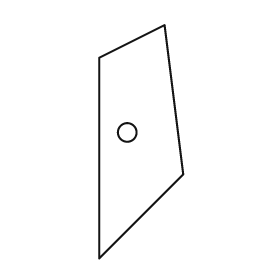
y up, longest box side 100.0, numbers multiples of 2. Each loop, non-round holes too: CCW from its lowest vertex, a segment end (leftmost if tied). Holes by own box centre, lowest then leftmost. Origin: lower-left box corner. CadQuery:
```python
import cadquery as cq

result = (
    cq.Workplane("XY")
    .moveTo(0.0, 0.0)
    .lineTo(36.0, 36.0)
    .lineTo(28.0, 100.0)
    .lineTo(0.0, 86.0)
    .close()
    .moveTo(12.0, 54.0)
    .circle(4.0)
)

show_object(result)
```